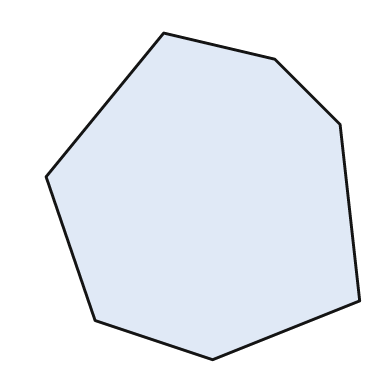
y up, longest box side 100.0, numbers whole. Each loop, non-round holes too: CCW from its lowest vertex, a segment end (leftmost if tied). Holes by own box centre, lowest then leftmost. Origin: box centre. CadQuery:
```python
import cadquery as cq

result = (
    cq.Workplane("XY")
    .moveTo(3.0, -50.0)
    .lineTo(48.0, -32.0)
    .lineTo(42.0, 22.0)
    .lineTo(22.0, 42.0)
    .lineTo(-12.0, 50.0)
    .lineTo(-48.0, 6.0)
    .lineTo(-33.0, -38.0)
    .close()
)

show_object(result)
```